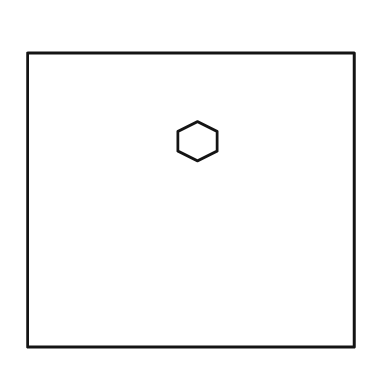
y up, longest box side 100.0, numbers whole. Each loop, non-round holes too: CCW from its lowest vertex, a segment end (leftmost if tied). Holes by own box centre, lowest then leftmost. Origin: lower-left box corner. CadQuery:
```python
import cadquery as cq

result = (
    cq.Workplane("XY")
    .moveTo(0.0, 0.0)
    .lineTo(100.0, 0.0)
    .lineTo(100.0, 90.0)
    .lineTo(0.0, 90.0)
    .close()
    .moveTo(52.0, 57.0)
    .lineTo(58.0, 60.0)
    .lineTo(58.0, 66.0)
    .lineTo(52.0, 69.0)
    .lineTo(46.0, 66.0)
    .lineTo(46.0, 60.0)
    .close()
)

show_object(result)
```